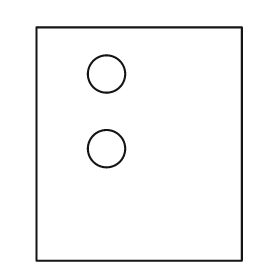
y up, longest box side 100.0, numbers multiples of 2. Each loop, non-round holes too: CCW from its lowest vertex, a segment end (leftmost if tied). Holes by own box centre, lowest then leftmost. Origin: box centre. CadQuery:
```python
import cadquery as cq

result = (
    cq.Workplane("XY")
    .moveTo(-44.0, -50.0)
    .lineTo(44.0, -50.0)
    .lineTo(44.0, 50.0)
    .lineTo(-44.0, 50.0)
    .close()
    .moveTo(-14.0, -2.0)
    .circle(8.0)
    .moveTo(-14.0, 30.0)
    .circle(8.0)
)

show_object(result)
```